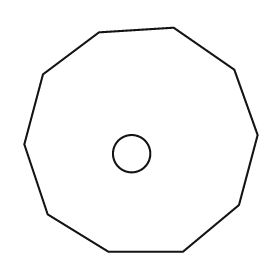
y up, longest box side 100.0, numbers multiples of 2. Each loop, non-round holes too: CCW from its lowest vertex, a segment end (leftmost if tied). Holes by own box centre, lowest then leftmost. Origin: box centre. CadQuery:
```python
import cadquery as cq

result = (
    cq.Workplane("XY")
    .moveTo(-14.0, -48.0)
    .lineTo(18.0, -48.0)
    .lineTo(42.0, -28.0)
    .lineTo(50.0, 2.0)
    .lineTo(40.0, 30.0)
    .lineTo(14.0, 48.0)
    .lineTo(-18.0, 46.0)
    .lineTo(-42.0, 28.0)
    .lineTo(-50.0, -2.0)
    .lineTo(-40.0, -32.0)
    .close()
    .moveTo(-4.0, -6.0)
    .circle(8.0)
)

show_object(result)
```